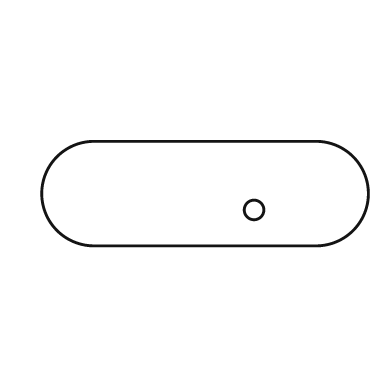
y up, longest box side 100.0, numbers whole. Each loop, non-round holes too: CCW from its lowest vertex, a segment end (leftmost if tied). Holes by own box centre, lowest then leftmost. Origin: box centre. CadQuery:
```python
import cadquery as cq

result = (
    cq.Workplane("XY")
    .moveTo(-34.0, -16.0)
    .lineTo(34.0, -16.0)
    .threePointArc((50.0, 0.0), (34.0, 16.0))
    .lineTo(-34.0, 16.0)
    .threePointArc((-50.0, 0.0), (-34.0, -16.0))
    .close()
    .moveTo(15.0, -5.0)
    .circle(3.0)
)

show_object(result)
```